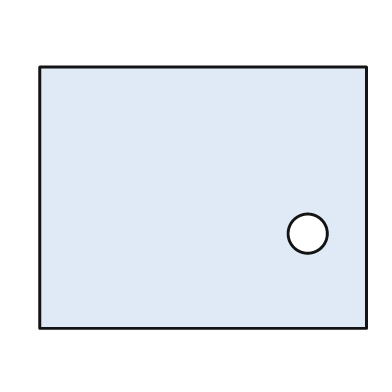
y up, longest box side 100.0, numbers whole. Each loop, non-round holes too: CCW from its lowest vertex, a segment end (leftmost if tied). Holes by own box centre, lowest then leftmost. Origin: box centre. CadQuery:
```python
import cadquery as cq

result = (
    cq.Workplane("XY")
    .moveTo(-50.0, -40.0)
    .lineTo(50.0, -40.0)
    .lineTo(50.0, 40.0)
    .lineTo(-50.0, 40.0)
    .close()
    .moveTo(32.0, -11.0)
    .circle(6.0)
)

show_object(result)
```